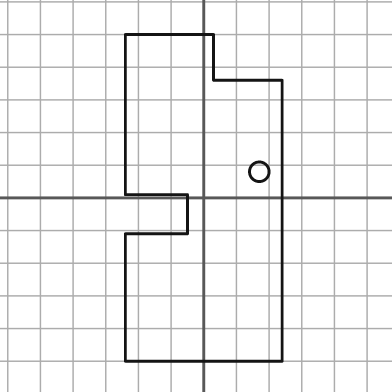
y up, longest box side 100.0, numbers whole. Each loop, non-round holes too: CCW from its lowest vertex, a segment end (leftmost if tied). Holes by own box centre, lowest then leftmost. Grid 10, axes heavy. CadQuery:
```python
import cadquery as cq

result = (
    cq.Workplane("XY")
    .moveTo(-24.0, -50.0)
    .lineTo(24.0, -50.0)
    .lineTo(24.0, 36.0)
    .lineTo(3.0, 36.0)
    .lineTo(3.0, 50.0)
    .lineTo(-24.0, 50.0)
    .lineTo(-24.0, 1.0)
    .lineTo(-5.0, 1.0)
    .lineTo(-5.0, -11.0)
    .lineTo(-24.0, -11.0)
    .close()
    .moveTo(17.0, 8.0)
    .circle(3.0)
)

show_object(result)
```